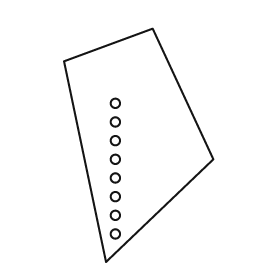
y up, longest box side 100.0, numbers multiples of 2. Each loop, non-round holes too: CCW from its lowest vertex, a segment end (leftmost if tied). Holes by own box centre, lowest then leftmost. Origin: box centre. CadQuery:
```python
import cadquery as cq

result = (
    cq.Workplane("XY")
    .moveTo(-14.0, -50.0)
    .lineTo(32.0, -6.0)
    .lineTo(6.0, 50.0)
    .lineTo(-32.0, 36.0)
    .close()
    .moveTo(-10.0, -38.0)
    .circle(2.0)
    .moveTo(-10.0, -30.0)
    .circle(2.0)
    .moveTo(-10.0, -22.0)
    .circle(2.0)
    .moveTo(-10.0, -14.0)
    .circle(2.0)
    .moveTo(-10.0, -6.0)
    .circle(2.0)
    .moveTo(-10.0, 2.0)
    .circle(2.0)
    .moveTo(-10.0, 10.0)
    .circle(2.0)
    .moveTo(-10.0, 18.0)
    .circle(2.0)
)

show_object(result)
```